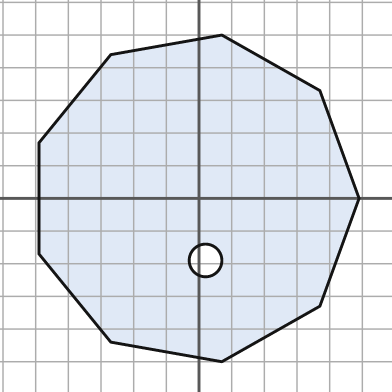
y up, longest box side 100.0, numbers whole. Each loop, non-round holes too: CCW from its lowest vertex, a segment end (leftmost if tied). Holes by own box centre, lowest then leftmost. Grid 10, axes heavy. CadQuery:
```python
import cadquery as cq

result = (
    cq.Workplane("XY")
    .moveTo(7.0, -50.0)
    .lineTo(37.0, -33.0)
    .lineTo(49.0, 0.0)
    .lineTo(37.0, 33.0)
    .lineTo(7.0, 50.0)
    .lineTo(-27.0, 44.0)
    .lineTo(-49.0, 17.0)
    .lineTo(-49.0, -17.0)
    .lineTo(-27.0, -44.0)
    .close()
    .moveTo(2.0, -19.0)
    .circle(5.0)
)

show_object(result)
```